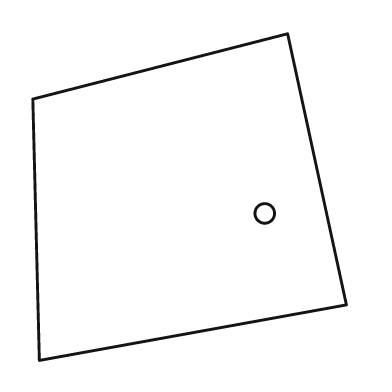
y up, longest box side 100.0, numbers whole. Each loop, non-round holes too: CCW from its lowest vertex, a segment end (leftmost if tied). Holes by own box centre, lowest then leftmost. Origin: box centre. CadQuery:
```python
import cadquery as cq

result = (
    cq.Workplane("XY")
    .moveTo(-46.0, -50.0)
    .lineTo(48.0, -33.0)
    .lineTo(30.0, 50.0)
    .lineTo(-48.0, 30.0)
    .close()
    .moveTo(23.0, -5.0)
    .circle(3.0)
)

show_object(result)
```